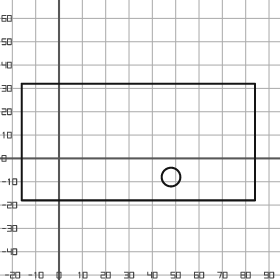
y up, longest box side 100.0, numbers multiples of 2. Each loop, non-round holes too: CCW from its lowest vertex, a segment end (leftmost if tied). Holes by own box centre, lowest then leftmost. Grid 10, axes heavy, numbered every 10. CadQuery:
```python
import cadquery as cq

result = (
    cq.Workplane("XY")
    .moveTo(-16.0, -18.0)
    .lineTo(84.0, -18.0)
    .lineTo(84.0, 32.0)
    .lineTo(-16.0, 32.0)
    .close()
    .moveTo(48.0, -8.0)
    .circle(4.0)
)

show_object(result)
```